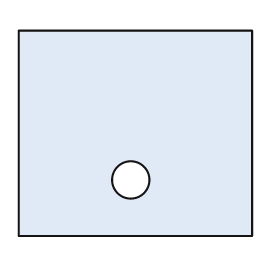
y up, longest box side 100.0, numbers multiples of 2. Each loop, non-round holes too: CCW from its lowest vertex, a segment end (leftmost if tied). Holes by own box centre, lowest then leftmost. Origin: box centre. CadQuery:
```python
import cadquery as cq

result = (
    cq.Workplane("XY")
    .moveTo(-50.0, -44.0)
    .lineTo(50.0, -44.0)
    .lineTo(50.0, 44.0)
    .lineTo(-50.0, 44.0)
    .close()
    .moveTo(-2.0, -20.0)
    .circle(8.0)
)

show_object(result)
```